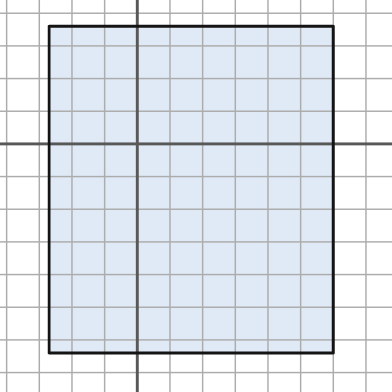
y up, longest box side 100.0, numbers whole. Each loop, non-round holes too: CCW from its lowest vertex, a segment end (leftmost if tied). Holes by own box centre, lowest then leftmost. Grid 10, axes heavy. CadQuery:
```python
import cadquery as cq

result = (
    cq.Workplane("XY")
    .moveTo(-27.0, -64.0)
    .lineTo(60.0, -64.0)
    .lineTo(60.0, 36.0)
    .lineTo(-27.0, 36.0)
    .close()
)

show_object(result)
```